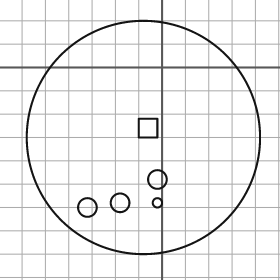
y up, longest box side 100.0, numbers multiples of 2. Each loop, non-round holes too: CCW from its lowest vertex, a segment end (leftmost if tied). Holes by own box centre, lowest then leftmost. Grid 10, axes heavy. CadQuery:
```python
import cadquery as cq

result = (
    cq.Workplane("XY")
    .moveTo(-8.0, -30.0)
    .circle(50.0)
    .moveTo(-32.0, -60.0)
    .circle(4.0)
    .moveTo(-18.0, -58.0)
    .circle(4.0)
    .moveTo(-2.0, -58.0)
    .circle(2.0)
    .moveTo(-2.0, -48.0)
    .circle(4.0)
    .moveTo(-10.0, -30.0)
    .lineTo(-2.0, -30.0)
    .lineTo(-2.0, -22.0)
    .lineTo(-10.0, -22.0)
    .close()
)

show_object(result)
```